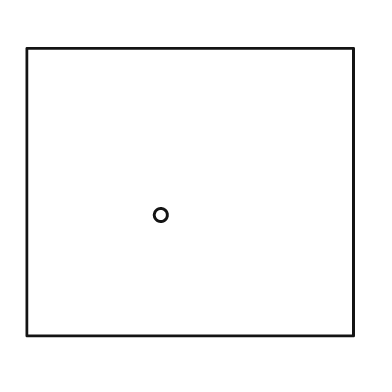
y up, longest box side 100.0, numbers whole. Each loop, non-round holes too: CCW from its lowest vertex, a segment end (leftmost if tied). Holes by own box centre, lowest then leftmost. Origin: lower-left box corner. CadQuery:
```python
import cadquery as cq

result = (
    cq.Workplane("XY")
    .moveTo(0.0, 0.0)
    .lineTo(100.0, 0.0)
    .lineTo(100.0, 88.0)
    .lineTo(0.0, 88.0)
    .close()
    .moveTo(41.0, 37.0)
    .circle(2.0)
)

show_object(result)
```